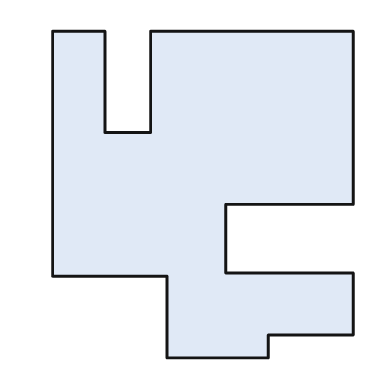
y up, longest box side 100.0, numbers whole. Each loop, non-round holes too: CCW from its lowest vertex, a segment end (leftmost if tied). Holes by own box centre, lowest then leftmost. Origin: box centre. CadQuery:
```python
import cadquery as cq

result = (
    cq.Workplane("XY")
    .moveTo(-11.0, -50.0)
    .lineTo(20.0, -50.0)
    .lineTo(20.0, -43.0)
    .lineTo(46.0, -43.0)
    .lineTo(46.0, -24.0)
    .lineTo(7.0, -24.0)
    .lineTo(7.0, -3.0)
    .lineTo(46.0, -3.0)
    .lineTo(46.0, 50.0)
    .lineTo(-16.0, 50.0)
    .lineTo(-16.0, 19.0)
    .lineTo(-30.0, 19.0)
    .lineTo(-30.0, 50.0)
    .lineTo(-46.0, 50.0)
    .lineTo(-46.0, -25.0)
    .lineTo(-11.0, -25.0)
    .close()
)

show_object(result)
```